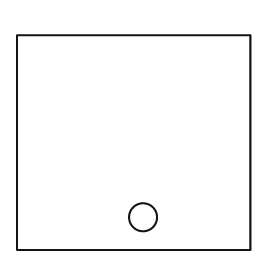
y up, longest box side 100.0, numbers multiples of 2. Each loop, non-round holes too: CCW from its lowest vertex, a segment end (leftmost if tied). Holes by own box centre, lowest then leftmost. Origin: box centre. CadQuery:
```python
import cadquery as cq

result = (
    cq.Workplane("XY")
    .moveTo(-50.0, -46.0)
    .lineTo(50.0, -46.0)
    .lineTo(50.0, 46.0)
    .lineTo(-50.0, 46.0)
    .close()
    .moveTo(4.0, -32.0)
    .circle(6.0)
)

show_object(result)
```